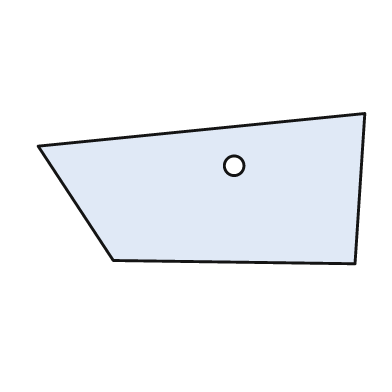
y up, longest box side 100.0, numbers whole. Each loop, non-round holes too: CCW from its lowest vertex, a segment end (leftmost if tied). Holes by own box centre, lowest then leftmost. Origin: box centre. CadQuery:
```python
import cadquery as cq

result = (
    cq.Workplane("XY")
    .moveTo(47.0, -23.0)
    .lineTo(50.0, 23.0)
    .lineTo(-50.0, 13.0)
    .lineTo(-27.0, -22.0)
    .close()
    .moveTo(10.0, 7.0)
    .circle(3.0)
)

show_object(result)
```